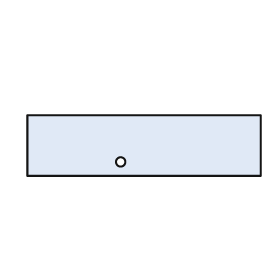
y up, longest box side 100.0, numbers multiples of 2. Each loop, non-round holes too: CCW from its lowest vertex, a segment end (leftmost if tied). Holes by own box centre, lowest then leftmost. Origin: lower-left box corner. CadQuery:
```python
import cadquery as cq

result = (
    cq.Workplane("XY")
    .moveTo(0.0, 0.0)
    .lineTo(100.0, 0.0)
    .lineTo(100.0, 26.0)
    .lineTo(0.0, 26.0)
    .close()
    .moveTo(40.0, 6.0)
    .circle(2.0)
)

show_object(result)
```